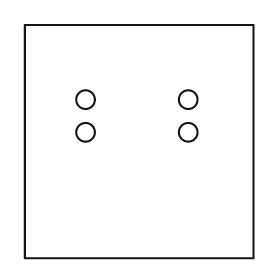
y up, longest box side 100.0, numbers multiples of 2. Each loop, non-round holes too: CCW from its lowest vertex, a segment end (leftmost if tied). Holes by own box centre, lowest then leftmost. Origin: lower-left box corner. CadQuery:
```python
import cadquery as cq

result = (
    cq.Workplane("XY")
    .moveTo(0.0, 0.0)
    .lineTo(98.0, 0.0)
    .lineTo(98.0, 100.0)
    .lineTo(0.0, 100.0)
    .close()
    .moveTo(26.0, 54.0)
    .circle(4.0)
    .moveTo(70.0, 54.0)
    .circle(4.0)
    .moveTo(26.0, 68.0)
    .circle(4.0)
    .moveTo(70.0, 68.0)
    .circle(4.0)
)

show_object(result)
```